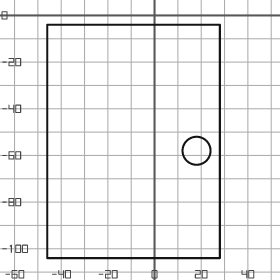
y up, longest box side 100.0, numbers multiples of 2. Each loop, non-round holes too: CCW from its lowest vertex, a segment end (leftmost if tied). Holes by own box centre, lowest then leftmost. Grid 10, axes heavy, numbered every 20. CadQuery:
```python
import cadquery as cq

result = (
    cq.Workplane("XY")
    .moveTo(-46.0, -104.0)
    .lineTo(28.0, -104.0)
    .lineTo(28.0, -4.0)
    .lineTo(-46.0, -4.0)
    .close()
    .moveTo(18.0, -58.0)
    .circle(6.0)
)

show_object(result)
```